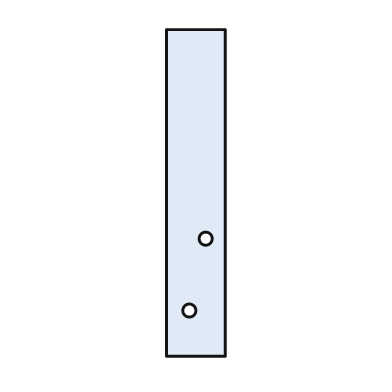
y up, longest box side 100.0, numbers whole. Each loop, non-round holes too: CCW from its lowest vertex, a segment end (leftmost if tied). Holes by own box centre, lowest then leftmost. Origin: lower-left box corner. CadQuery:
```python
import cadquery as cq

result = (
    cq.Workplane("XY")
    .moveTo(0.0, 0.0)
    .lineTo(18.0, 0.0)
    .lineTo(18.0, 100.0)
    .lineTo(0.0, 100.0)
    .close()
    .moveTo(7.0, 14.0)
    .circle(2.0)
    .moveTo(12.0, 36.0)
    .circle(2.0)
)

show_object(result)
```